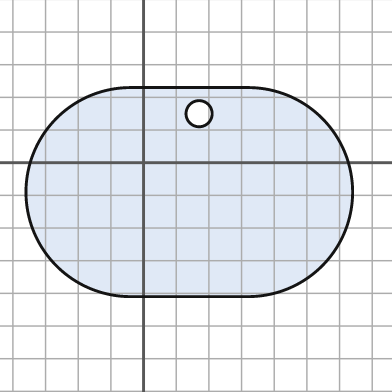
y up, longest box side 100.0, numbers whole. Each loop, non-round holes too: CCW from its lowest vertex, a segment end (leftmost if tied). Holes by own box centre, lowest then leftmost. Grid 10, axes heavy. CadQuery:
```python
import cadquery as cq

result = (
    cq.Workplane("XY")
    .moveTo(-4.0, -41.0)
    .lineTo(32.0, -41.0)
    .threePointArc((64.0, -9.0), (32.0, 23.0))
    .lineTo(-4.0, 23.0)
    .threePointArc((-36.0, -9.0), (-4.0, -41.0))
    .close()
    .moveTo(17.0, 15.0)
    .circle(4.0)
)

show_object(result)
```